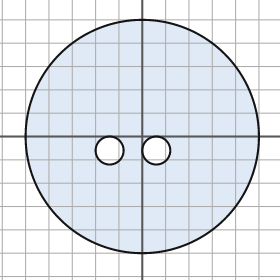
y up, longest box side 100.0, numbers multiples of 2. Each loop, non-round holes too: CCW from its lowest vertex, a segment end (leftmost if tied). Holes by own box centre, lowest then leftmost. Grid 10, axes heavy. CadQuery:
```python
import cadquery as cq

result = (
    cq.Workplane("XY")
    .moveTo(0.0, 0.0)
    .circle(50.0)
    .moveTo(-14.0, -6.0)
    .circle(6.0)
    .moveTo(6.0, -6.0)
    .circle(6.0)
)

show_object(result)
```